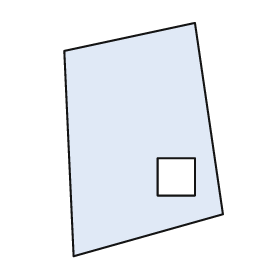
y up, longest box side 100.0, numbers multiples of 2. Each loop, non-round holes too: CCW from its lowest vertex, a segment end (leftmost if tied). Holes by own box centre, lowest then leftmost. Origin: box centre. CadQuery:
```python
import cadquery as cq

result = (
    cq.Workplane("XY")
    .moveTo(-30.0, -50.0)
    .lineTo(34.0, -32.0)
    .lineTo(22.0, 50.0)
    .lineTo(-34.0, 38.0)
    .close()
    .moveTo(6.0, -24.0)
    .lineTo(22.0, -24.0)
    .lineTo(22.0, -8.0)
    .lineTo(6.0, -8.0)
    .close()
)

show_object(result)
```